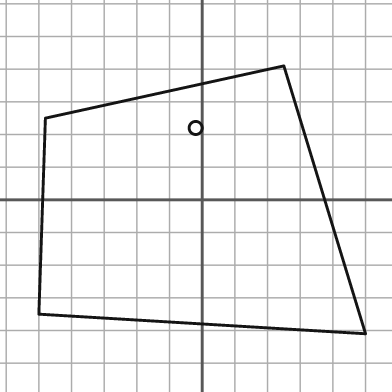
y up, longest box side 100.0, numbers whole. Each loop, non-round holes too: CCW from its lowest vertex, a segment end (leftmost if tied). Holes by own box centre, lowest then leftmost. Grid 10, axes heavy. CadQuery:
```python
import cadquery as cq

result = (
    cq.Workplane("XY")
    .moveTo(50.0, -41.0)
    .lineTo(25.0, 41.0)
    .lineTo(-48.0, 25.0)
    .lineTo(-50.0, -35.0)
    .close()
    .moveTo(-2.0, 22.0)
    .circle(2.0)
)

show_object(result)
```